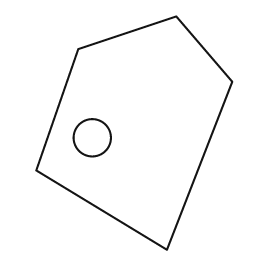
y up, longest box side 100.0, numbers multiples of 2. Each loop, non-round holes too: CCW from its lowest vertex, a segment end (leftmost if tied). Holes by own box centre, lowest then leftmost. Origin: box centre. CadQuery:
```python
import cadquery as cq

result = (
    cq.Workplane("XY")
    .moveTo(14.0, -50.0)
    .lineTo(42.0, 22.0)
    .lineTo(18.0, 50.0)
    .lineTo(-24.0, 36.0)
    .lineTo(-42.0, -16.0)
    .close()
    .moveTo(-18.0, -2.0)
    .circle(8.0)
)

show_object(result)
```